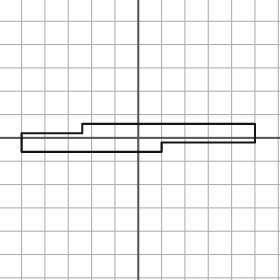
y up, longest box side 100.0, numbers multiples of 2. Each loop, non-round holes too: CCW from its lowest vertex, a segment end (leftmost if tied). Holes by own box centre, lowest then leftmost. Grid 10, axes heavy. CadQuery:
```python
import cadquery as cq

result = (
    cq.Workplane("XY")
    .moveTo(-50.0, -6.0)
    .lineTo(10.0, -6.0)
    .lineTo(10.0, -2.0)
    .lineTo(50.0, -2.0)
    .lineTo(50.0, 6.0)
    .lineTo(-24.0, 6.0)
    .lineTo(-24.0, 2.0)
    .lineTo(-50.0, 2.0)
    .close()
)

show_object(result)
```